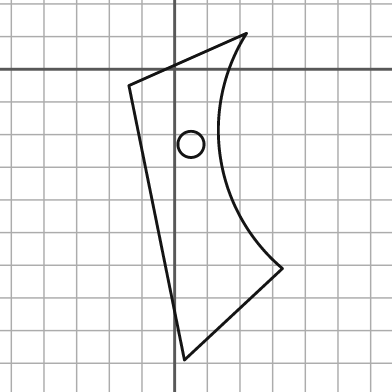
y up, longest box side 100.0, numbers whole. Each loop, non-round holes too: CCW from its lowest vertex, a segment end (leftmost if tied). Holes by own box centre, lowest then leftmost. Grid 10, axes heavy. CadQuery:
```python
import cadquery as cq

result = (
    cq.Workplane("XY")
    .moveTo(3.0, -89.0)
    .lineTo(33.0, -61.0)
    .threePointArc((14.0, -27.0), (22.0, 11.0))
    .lineTo(-14.0, -5.0)
    .close()
    .moveTo(5.0, -23.0)
    .circle(4.0)
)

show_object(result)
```